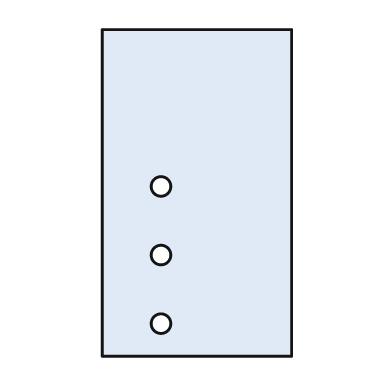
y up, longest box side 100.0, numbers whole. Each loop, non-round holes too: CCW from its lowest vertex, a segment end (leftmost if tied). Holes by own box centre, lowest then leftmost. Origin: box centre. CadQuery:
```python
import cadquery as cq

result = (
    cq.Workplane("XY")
    .moveTo(-29.0, -50.0)
    .lineTo(29.0, -50.0)
    .lineTo(29.0, 50.0)
    .lineTo(-29.0, 50.0)
    .close()
    .moveTo(-11.0, -40.0)
    .circle(3.0)
    .moveTo(-11.0, -19.0)
    .circle(3.0)
    .moveTo(-11.0, 2.0)
    .circle(3.0)
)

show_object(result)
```